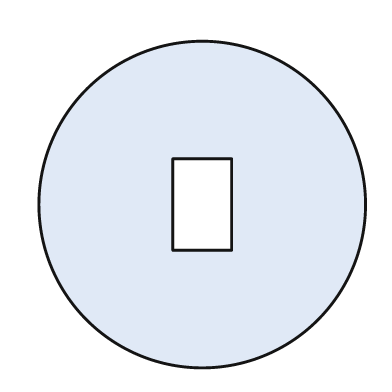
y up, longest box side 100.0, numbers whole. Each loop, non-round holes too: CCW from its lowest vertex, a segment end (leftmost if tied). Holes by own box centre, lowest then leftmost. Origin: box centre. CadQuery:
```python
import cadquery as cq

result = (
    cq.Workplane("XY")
    .moveTo(0.0, 0.0)
    .circle(50.0)
    .moveTo(-9.0, -14.0)
    .lineTo(9.0, -14.0)
    .lineTo(9.0, 14.0)
    .lineTo(-9.0, 14.0)
    .close()
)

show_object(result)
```